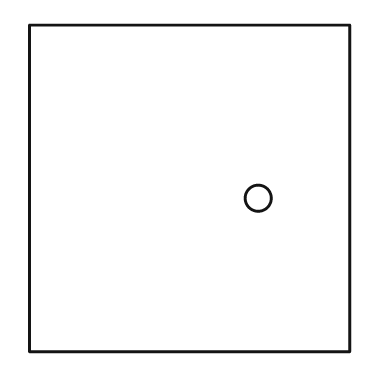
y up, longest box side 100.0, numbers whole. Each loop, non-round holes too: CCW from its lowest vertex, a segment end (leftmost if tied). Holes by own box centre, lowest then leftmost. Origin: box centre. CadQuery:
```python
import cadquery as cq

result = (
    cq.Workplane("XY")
    .moveTo(-49.0, -50.0)
    .lineTo(49.0, -50.0)
    .lineTo(49.0, 50.0)
    .lineTo(-49.0, 50.0)
    .close()
    .moveTo(21.0, -3.0)
    .circle(4.0)
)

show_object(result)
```